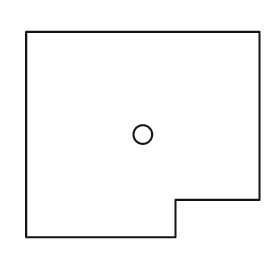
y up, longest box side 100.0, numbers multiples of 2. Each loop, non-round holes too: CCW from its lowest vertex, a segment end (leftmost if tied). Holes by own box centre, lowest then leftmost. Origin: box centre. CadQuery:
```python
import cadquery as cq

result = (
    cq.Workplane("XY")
    .moveTo(-50.0, -44.0)
    .lineTo(14.0, -44.0)
    .lineTo(14.0, -28.0)
    .lineTo(50.0, -28.0)
    .lineTo(50.0, 44.0)
    .lineTo(-50.0, 44.0)
    .close()
    .moveTo(0.0, 0.0)
    .circle(4.0)
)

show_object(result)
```